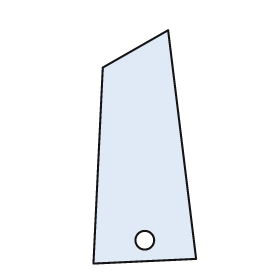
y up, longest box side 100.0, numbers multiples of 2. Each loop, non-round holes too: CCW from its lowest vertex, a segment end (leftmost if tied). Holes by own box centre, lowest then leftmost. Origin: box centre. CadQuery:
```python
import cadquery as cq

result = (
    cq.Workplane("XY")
    .moveTo(-22.0, -50.0)
    .lineTo(22.0, -48.0)
    .lineTo(10.0, 50.0)
    .lineTo(-18.0, 34.0)
    .close()
    .moveTo(0.0, -40.0)
    .circle(4.0)
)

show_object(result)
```